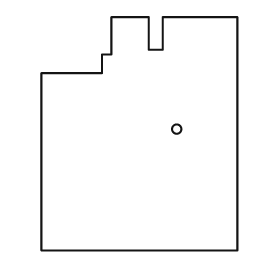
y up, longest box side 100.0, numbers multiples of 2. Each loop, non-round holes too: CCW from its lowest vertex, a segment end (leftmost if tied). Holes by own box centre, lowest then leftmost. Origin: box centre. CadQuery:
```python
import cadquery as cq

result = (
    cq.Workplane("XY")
    .moveTo(-42.0, -50.0)
    .lineTo(42.0, -50.0)
    .lineTo(42.0, 50.0)
    .lineTo(10.0, 50.0)
    .lineTo(10.0, 36.0)
    .lineTo(4.0, 36.0)
    .lineTo(4.0, 50.0)
    .lineTo(-12.0, 50.0)
    .lineTo(-12.0, 34.0)
    .lineTo(-16.0, 34.0)
    .lineTo(-16.0, 26.0)
    .lineTo(-42.0, 26.0)
    .close()
    .moveTo(16.0, 2.0)
    .circle(2.0)
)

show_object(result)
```